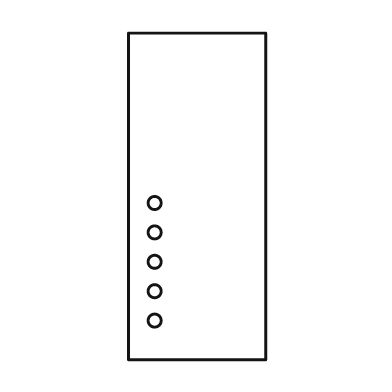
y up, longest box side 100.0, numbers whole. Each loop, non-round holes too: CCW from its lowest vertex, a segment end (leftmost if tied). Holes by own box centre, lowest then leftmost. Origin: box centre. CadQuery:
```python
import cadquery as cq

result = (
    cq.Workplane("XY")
    .moveTo(-21.0, -50.0)
    .lineTo(21.0, -50.0)
    .lineTo(21.0, 50.0)
    .lineTo(-21.0, 50.0)
    .close()
    .moveTo(-13.0, -38.0)
    .circle(2.0)
    .moveTo(-13.0, -29.0)
    .circle(2.0)
    .moveTo(-13.0, -20.0)
    .circle(2.0)
    .moveTo(-13.0, -11.0)
    .circle(2.0)
    .moveTo(-13.0, -2.0)
    .circle(2.0)
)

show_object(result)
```